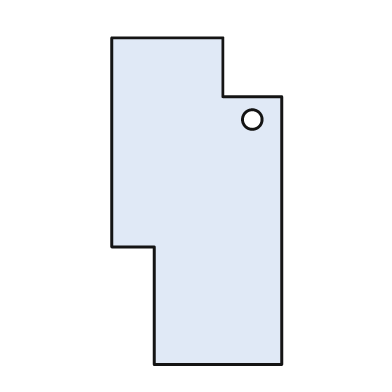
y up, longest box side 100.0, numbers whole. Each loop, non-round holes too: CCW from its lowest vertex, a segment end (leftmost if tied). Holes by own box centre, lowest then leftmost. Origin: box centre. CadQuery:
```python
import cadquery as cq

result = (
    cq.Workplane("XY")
    .moveTo(-13.0, -50.0)
    .lineTo(26.0, -50.0)
    .lineTo(26.0, 32.0)
    .lineTo(8.0, 32.0)
    .lineTo(8.0, 50.0)
    .lineTo(-26.0, 50.0)
    .lineTo(-26.0, -14.0)
    .lineTo(-13.0, -14.0)
    .close()
    .moveTo(17.0, 25.0)
    .circle(3.0)
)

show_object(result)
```